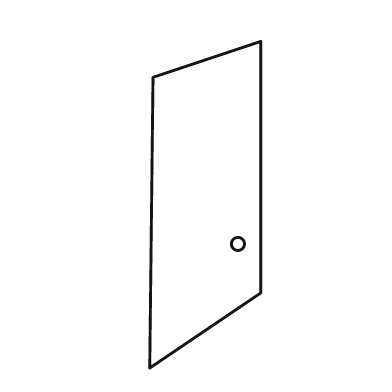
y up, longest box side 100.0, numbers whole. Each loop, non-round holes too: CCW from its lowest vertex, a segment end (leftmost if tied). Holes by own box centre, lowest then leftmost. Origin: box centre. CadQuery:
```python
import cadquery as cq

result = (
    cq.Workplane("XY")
    .moveTo(-17.0, -50.0)
    .lineTo(17.0, -27.0)
    .lineTo(17.0, 50.0)
    .lineTo(-16.0, 39.0)
    .close()
    .moveTo(10.0, -12.0)
    .circle(2.0)
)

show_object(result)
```